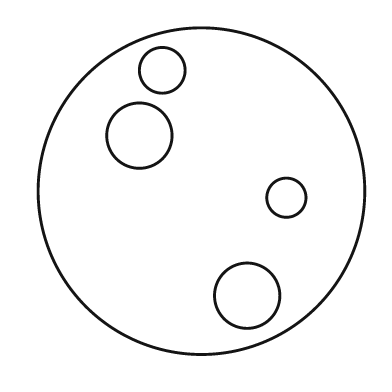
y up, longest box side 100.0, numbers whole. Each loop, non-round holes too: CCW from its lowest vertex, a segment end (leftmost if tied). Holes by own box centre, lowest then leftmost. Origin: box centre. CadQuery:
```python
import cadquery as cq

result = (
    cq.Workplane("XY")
    .moveTo(0.0, 0.0)
    .circle(50.0)
    .moveTo(14.0, -32.0)
    .circle(10.0)
    .moveTo(26.0, -2.0)
    .circle(6.0)
    .moveTo(-19.0, 17.0)
    .circle(10.0)
    .moveTo(-12.0, 37.0)
    .circle(7.0)
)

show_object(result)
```